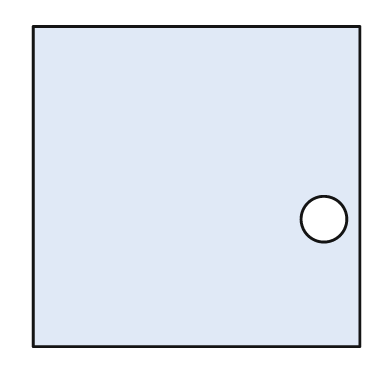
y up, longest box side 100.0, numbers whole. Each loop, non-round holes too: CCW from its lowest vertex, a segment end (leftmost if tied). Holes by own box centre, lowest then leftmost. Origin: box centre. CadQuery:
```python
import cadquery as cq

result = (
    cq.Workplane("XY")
    .moveTo(-50.0, -49.0)
    .lineTo(50.0, -49.0)
    .lineTo(50.0, 49.0)
    .lineTo(-50.0, 49.0)
    .close()
    .moveTo(39.0, -10.0)
    .circle(7.0)
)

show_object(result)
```